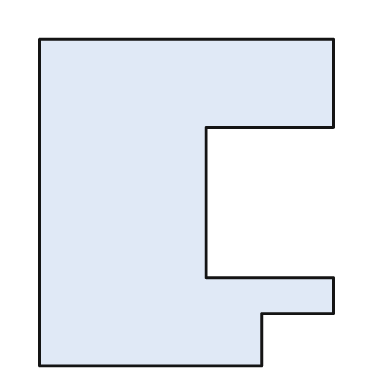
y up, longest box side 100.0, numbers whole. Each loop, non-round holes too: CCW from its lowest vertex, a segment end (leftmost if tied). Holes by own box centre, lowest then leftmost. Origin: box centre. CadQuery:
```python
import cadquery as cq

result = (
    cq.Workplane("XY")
    .moveTo(-45.0, -50.0)
    .lineTo(23.0, -50.0)
    .lineTo(23.0, -34.0)
    .lineTo(45.0, -34.0)
    .lineTo(45.0, -23.0)
    .lineTo(6.0, -23.0)
    .lineTo(6.0, 23.0)
    .lineTo(45.0, 23.0)
    .lineTo(45.0, 50.0)
    .lineTo(-45.0, 50.0)
    .close()
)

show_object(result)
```